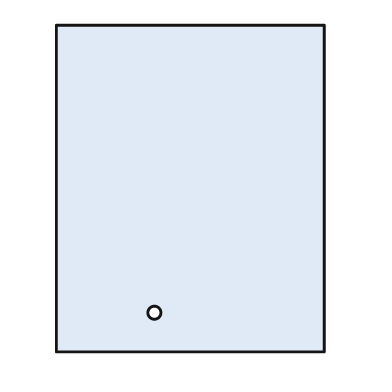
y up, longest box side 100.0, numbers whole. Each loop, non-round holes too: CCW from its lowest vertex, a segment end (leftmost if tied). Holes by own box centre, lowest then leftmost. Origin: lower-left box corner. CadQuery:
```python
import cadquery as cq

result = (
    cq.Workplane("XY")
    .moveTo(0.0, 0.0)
    .lineTo(82.0, 0.0)
    .lineTo(82.0, 100.0)
    .lineTo(0.0, 100.0)
    .close()
    .moveTo(30.0, 12.0)
    .circle(2.0)
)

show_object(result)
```